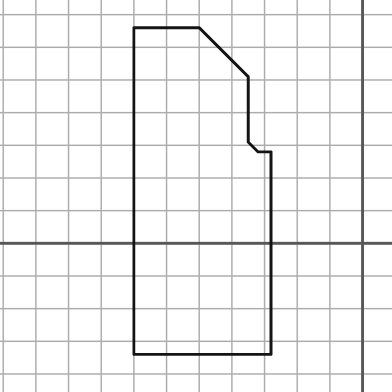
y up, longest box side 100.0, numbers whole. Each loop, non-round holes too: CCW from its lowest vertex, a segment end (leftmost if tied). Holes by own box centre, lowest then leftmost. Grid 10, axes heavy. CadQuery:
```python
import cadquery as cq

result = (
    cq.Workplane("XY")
    .moveTo(-70.0, -34.0)
    .lineTo(-28.0, -34.0)
    .lineTo(-28.0, 28.0)
    .lineTo(-32.0, 28.0)
    .lineTo(-35.0, 31.0)
    .lineTo(-35.0, 51.0)
    .lineTo(-50.0, 66.0)
    .lineTo(-70.0, 66.0)
    .close()
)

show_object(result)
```